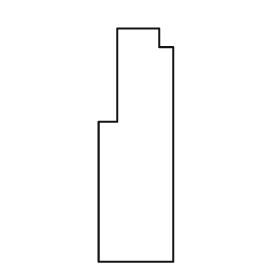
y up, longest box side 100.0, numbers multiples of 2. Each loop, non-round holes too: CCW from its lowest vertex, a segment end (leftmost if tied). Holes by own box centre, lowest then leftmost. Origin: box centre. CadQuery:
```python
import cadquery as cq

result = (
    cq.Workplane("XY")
    .moveTo(-16.0, -50.0)
    .lineTo(16.0, -50.0)
    .lineTo(16.0, 42.0)
    .lineTo(10.0, 42.0)
    .lineTo(10.0, 50.0)
    .lineTo(-8.0, 50.0)
    .lineTo(-8.0, 10.0)
    .lineTo(-16.0, 10.0)
    .close()
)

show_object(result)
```